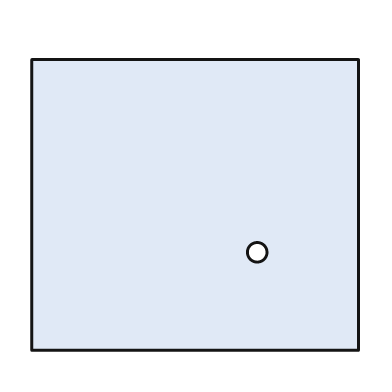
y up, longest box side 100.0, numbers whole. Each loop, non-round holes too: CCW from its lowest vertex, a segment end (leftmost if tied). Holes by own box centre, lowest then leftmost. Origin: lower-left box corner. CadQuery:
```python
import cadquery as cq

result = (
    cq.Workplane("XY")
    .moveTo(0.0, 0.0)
    .lineTo(100.0, 0.0)
    .lineTo(100.0, 89.0)
    .lineTo(0.0, 89.0)
    .close()
    .moveTo(69.0, 30.0)
    .circle(3.0)
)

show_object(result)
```